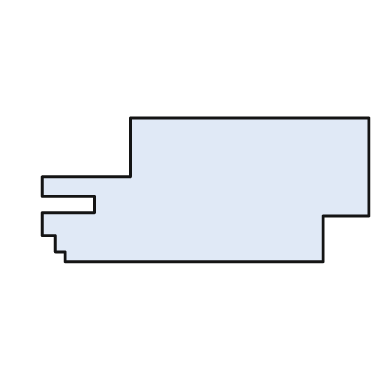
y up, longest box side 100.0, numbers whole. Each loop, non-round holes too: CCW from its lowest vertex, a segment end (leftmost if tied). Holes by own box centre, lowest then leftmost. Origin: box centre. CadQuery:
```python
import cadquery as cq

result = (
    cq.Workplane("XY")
    .moveTo(-43.0, -22.0)
    .lineTo(36.0, -22.0)
    .lineTo(36.0, -8.0)
    .lineTo(50.0, -8.0)
    .lineTo(50.0, 22.0)
    .lineTo(-23.0, 22.0)
    .lineTo(-23.0, 4.0)
    .lineTo(-50.0, 4.0)
    .lineTo(-50.0, -2.0)
    .lineTo(-34.0, -2.0)
    .lineTo(-34.0, -7.0)
    .lineTo(-50.0, -7.0)
    .lineTo(-50.0, -14.0)
    .lineTo(-46.0, -14.0)
    .lineTo(-46.0, -19.0)
    .lineTo(-43.0, -19.0)
    .close()
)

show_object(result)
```